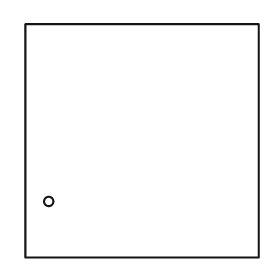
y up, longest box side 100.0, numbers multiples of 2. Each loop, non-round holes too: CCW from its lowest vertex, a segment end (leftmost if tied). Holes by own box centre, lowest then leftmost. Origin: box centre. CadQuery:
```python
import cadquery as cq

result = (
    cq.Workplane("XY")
    .moveTo(-50.0, -50.0)
    .lineTo(50.0, -50.0)
    .lineTo(50.0, 50.0)
    .lineTo(-50.0, 50.0)
    .close()
    .moveTo(-40.0, -26.0)
    .circle(2.0)
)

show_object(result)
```